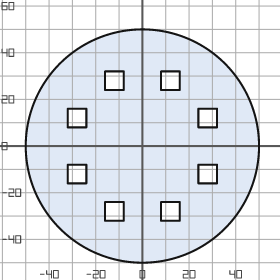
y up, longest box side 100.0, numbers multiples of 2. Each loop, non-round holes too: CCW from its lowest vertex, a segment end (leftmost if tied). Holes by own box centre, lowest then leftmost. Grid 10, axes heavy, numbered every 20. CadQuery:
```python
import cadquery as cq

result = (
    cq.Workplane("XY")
    .moveTo(0.0, 0.0)
    .circle(50.0)
    .moveTo(-16.0, -32.0)
    .lineTo(-8.0, -32.0)
    .lineTo(-8.0, -24.0)
    .lineTo(-16.0, -24.0)
    .close()
    .moveTo(8.0, -32.0)
    .lineTo(16.0, -32.0)
    .lineTo(16.0, -24.0)
    .lineTo(8.0, -24.0)
    .close()
    .moveTo(-32.0, -16.0)
    .lineTo(-24.0, -16.0)
    .lineTo(-24.0, -8.0)
    .lineTo(-32.0, -8.0)
    .close()
    .moveTo(24.0, -16.0)
    .lineTo(32.0, -16.0)
    .lineTo(32.0, -8.0)
    .lineTo(24.0, -8.0)
    .close()
    .moveTo(-32.0, 8.0)
    .lineTo(-24.0, 8.0)
    .lineTo(-24.0, 16.0)
    .lineTo(-32.0, 16.0)
    .close()
    .moveTo(24.0, 8.0)
    .lineTo(32.0, 8.0)
    .lineTo(32.0, 16.0)
    .lineTo(24.0, 16.0)
    .close()
    .moveTo(-16.0, 24.0)
    .lineTo(-8.0, 24.0)
    .lineTo(-8.0, 32.0)
    .lineTo(-16.0, 32.0)
    .close()
    .moveTo(8.0, 24.0)
    .lineTo(16.0, 24.0)
    .lineTo(16.0, 32.0)
    .lineTo(8.0, 32.0)
    .close()
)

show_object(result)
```